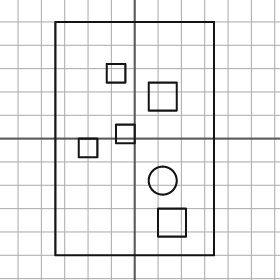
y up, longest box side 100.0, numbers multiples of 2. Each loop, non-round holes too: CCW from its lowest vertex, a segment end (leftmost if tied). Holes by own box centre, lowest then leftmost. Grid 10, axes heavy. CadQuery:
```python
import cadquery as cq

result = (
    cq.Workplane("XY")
    .moveTo(-34.0, -50.0)
    .lineTo(34.0, -50.0)
    .lineTo(34.0, 50.0)
    .lineTo(-34.0, 50.0)
    .close()
    .moveTo(10.0, -42.0)
    .lineTo(22.0, -42.0)
    .lineTo(22.0, -30.0)
    .lineTo(10.0, -30.0)
    .close()
    .moveTo(12.0, -18.0)
    .circle(6.0)
    .moveTo(-24.0, -8.0)
    .lineTo(-16.0, -8.0)
    .lineTo(-16.0, 0.0)
    .lineTo(-24.0, 0.0)
    .close()
    .moveTo(-8.0, -2.0)
    .lineTo(0.0, -2.0)
    .lineTo(0.0, 6.0)
    .lineTo(-8.0, 6.0)
    .close()
    .moveTo(6.0, 12.0)
    .lineTo(18.0, 12.0)
    .lineTo(18.0, 24.0)
    .lineTo(6.0, 24.0)
    .close()
    .moveTo(-12.0, 24.0)
    .lineTo(-4.0, 24.0)
    .lineTo(-4.0, 32.0)
    .lineTo(-12.0, 32.0)
    .close()
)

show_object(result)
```